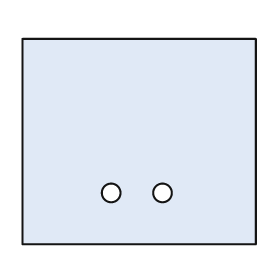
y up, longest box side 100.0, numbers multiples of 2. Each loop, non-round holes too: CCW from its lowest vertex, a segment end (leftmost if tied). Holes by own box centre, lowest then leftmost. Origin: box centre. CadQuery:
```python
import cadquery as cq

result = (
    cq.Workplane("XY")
    .moveTo(-50.0, -44.0)
    .lineTo(50.0, -44.0)
    .lineTo(50.0, 44.0)
    .lineTo(-50.0, 44.0)
    .close()
    .moveTo(-12.0, -22.0)
    .circle(4.0)
    .moveTo(10.0, -22.0)
    .circle(4.0)
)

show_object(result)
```